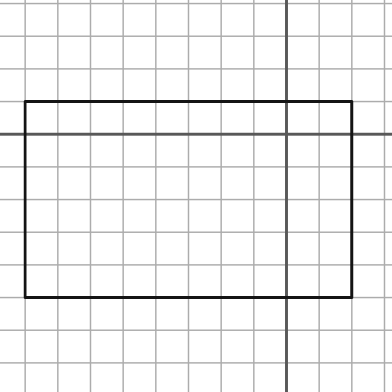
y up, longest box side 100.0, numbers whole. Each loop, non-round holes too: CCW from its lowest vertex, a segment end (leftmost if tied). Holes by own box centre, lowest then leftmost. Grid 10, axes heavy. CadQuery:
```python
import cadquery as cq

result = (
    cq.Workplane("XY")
    .moveTo(-80.0, -50.0)
    .lineTo(20.0, -50.0)
    .lineTo(20.0, 10.0)
    .lineTo(-80.0, 10.0)
    .close()
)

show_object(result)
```